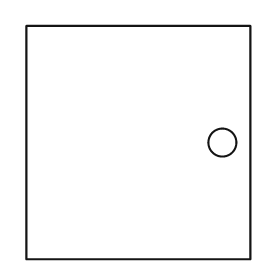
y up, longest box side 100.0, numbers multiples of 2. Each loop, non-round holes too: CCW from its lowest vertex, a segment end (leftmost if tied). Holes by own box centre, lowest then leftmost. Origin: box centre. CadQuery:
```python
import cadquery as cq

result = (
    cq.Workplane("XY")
    .moveTo(-48.0, -50.0)
    .lineTo(48.0, -50.0)
    .lineTo(48.0, 50.0)
    .lineTo(-48.0, 50.0)
    .close()
    .moveTo(36.0, 0.0)
    .circle(6.0)
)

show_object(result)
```